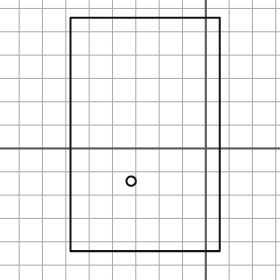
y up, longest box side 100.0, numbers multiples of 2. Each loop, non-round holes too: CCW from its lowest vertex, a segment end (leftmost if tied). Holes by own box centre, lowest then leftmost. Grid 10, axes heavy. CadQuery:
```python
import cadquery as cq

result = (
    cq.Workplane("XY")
    .moveTo(-58.0, -44.0)
    .lineTo(6.0, -44.0)
    .lineTo(6.0, 56.0)
    .lineTo(-58.0, 56.0)
    .close()
    .moveTo(-32.0, -14.0)
    .circle(2.0)
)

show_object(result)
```